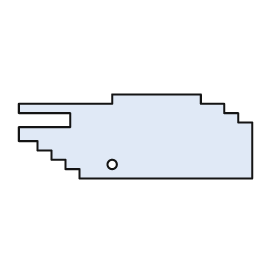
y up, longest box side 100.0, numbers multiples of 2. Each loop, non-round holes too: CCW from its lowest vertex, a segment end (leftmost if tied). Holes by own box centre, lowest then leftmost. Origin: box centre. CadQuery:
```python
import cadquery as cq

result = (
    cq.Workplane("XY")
    .moveTo(-24.0, -18.0)
    .lineTo(50.0, -18.0)
    .lineTo(50.0, 6.0)
    .lineTo(44.0, 6.0)
    .lineTo(44.0, 10.0)
    .lineTo(38.0, 10.0)
    .lineTo(38.0, 14.0)
    .lineTo(28.0, 14.0)
    .lineTo(28.0, 18.0)
    .lineTo(-10.0, 18.0)
    .lineTo(-10.0, 14.0)
    .lineTo(-50.0, 14.0)
    .lineTo(-50.0, 10.0)
    .lineTo(-28.0, 10.0)
    .lineTo(-28.0, 4.0)
    .lineTo(-50.0, 4.0)
    .lineTo(-50.0, -2.0)
    .lineTo(-42.0, -2.0)
    .lineTo(-42.0, -6.0)
    .lineTo(-36.0, -6.0)
    .lineTo(-36.0, -10.0)
    .lineTo(-30.0, -10.0)
    .lineTo(-30.0, -14.0)
    .lineTo(-24.0, -14.0)
    .close()
    .moveTo(-10.0, -12.0)
    .circle(2.0)
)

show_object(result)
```